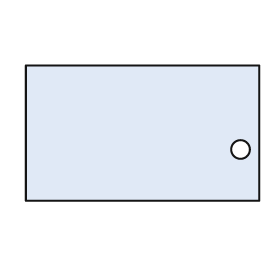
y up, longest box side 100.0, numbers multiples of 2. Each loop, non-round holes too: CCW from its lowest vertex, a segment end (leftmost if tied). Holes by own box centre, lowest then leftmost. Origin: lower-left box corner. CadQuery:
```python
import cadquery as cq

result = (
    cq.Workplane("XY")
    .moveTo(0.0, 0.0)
    .lineTo(100.0, 0.0)
    .lineTo(100.0, 58.0)
    .lineTo(0.0, 58.0)
    .close()
    .moveTo(92.0, 22.0)
    .circle(4.0)
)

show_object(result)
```